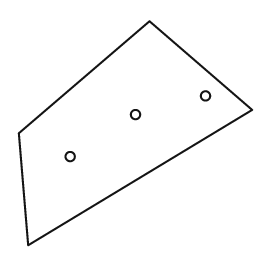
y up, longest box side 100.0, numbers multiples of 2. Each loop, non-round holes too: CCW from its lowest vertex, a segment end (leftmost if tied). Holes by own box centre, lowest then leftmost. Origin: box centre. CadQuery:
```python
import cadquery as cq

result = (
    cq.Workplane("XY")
    .moveTo(-46.0, -48.0)
    .lineTo(50.0, 10.0)
    .lineTo(6.0, 48.0)
    .lineTo(-50.0, 0.0)
    .close()
    .moveTo(-28.0, -10.0)
    .circle(2.0)
    .moveTo(0.0, 8.0)
    .circle(2.0)
    .moveTo(30.0, 16.0)
    .circle(2.0)
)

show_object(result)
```